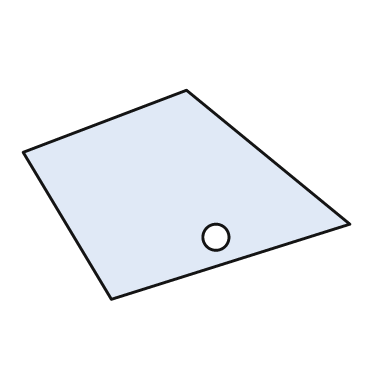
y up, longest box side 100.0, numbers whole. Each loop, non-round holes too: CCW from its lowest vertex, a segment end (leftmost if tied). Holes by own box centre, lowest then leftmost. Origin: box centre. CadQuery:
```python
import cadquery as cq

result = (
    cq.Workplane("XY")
    .moveTo(-23.0, -32.0)
    .lineTo(50.0, -9.0)
    .lineTo(0.0, 32.0)
    .lineTo(-50.0, 13.0)
    .close()
    .moveTo(9.0, -13.0)
    .circle(4.0)
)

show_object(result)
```